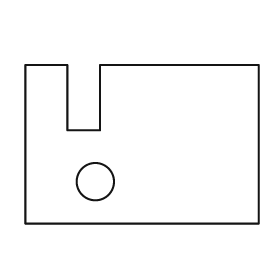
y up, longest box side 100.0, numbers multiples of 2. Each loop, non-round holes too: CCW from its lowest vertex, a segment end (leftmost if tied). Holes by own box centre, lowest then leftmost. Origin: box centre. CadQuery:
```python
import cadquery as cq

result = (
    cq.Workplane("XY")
    .moveTo(-50.0, -34.0)
    .lineTo(50.0, -34.0)
    .lineTo(50.0, 34.0)
    .lineTo(-18.0, 34.0)
    .lineTo(-18.0, 6.0)
    .lineTo(-32.0, 6.0)
    .lineTo(-32.0, 34.0)
    .lineTo(-50.0, 34.0)
    .close()
    .moveTo(-20.0, -16.0)
    .circle(8.0)
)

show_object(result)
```